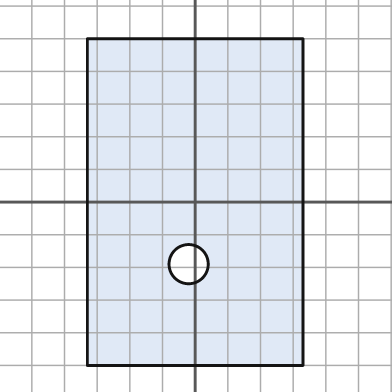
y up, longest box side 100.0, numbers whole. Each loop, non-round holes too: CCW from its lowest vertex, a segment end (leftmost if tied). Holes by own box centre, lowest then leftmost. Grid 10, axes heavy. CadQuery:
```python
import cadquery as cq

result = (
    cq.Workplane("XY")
    .moveTo(-33.0, -50.0)
    .lineTo(33.0, -50.0)
    .lineTo(33.0, 50.0)
    .lineTo(-33.0, 50.0)
    .close()
    .moveTo(-2.0, -19.0)
    .circle(6.0)
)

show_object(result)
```